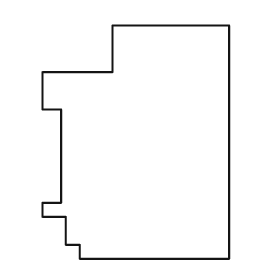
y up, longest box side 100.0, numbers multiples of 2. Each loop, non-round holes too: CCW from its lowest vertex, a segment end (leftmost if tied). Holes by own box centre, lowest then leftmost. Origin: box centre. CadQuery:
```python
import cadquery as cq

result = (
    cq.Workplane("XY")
    .moveTo(-24.0, -50.0)
    .lineTo(40.0, -50.0)
    .lineTo(40.0, 50.0)
    .lineTo(-10.0, 50.0)
    .lineTo(-10.0, 30.0)
    .lineTo(-40.0, 30.0)
    .lineTo(-40.0, 14.0)
    .lineTo(-32.0, 14.0)
    .lineTo(-32.0, -26.0)
    .lineTo(-40.0, -26.0)
    .lineTo(-40.0, -32.0)
    .lineTo(-30.0, -32.0)
    .lineTo(-30.0, -44.0)
    .lineTo(-24.0, -44.0)
    .close()
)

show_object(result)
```